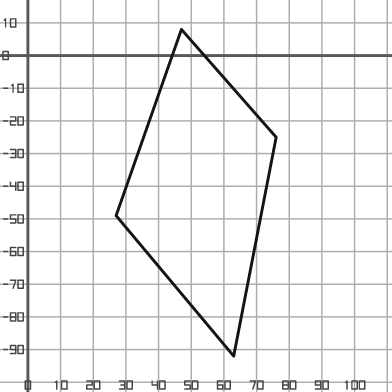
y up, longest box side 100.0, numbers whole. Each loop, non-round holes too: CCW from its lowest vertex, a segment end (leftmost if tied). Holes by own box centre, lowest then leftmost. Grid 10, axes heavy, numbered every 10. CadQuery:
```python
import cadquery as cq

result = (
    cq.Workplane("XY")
    .moveTo(63.0, -92.0)
    .lineTo(76.0, -25.0)
    .lineTo(47.0, 8.0)
    .lineTo(27.0, -49.0)
    .close()
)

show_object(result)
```